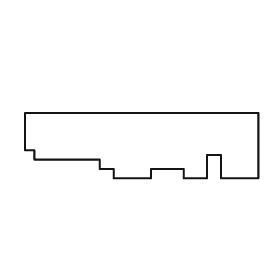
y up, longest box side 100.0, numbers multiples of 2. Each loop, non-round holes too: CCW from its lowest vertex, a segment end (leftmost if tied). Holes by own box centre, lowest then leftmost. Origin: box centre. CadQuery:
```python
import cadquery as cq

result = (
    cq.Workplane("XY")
    .moveTo(-12.0, -14.0)
    .lineTo(4.0, -14.0)
    .lineTo(4.0, -10.0)
    .lineTo(18.0, -10.0)
    .lineTo(18.0, -14.0)
    .lineTo(28.0, -14.0)
    .lineTo(28.0, -4.0)
    .lineTo(34.0, -4.0)
    .lineTo(34.0, -14.0)
    .lineTo(50.0, -14.0)
    .lineTo(50.0, 14.0)
    .lineTo(-50.0, 14.0)
    .lineTo(-50.0, -2.0)
    .lineTo(-46.0, -2.0)
    .lineTo(-46.0, -6.0)
    .lineTo(-18.0, -6.0)
    .lineTo(-18.0, -10.0)
    .lineTo(-12.0, -10.0)
    .close()
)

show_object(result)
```